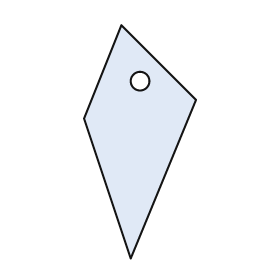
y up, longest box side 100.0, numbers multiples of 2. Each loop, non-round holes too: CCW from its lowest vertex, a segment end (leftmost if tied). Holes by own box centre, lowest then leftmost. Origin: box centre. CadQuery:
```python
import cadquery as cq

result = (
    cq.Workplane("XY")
    .moveTo(-4.0, -50.0)
    .lineTo(24.0, 18.0)
    .lineTo(-8.0, 50.0)
    .lineTo(-24.0, 10.0)
    .close()
    .moveTo(0.0, 26.0)
    .circle(4.0)
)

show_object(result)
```